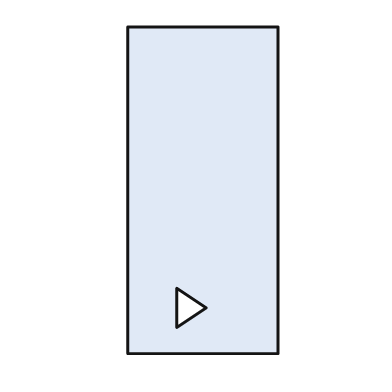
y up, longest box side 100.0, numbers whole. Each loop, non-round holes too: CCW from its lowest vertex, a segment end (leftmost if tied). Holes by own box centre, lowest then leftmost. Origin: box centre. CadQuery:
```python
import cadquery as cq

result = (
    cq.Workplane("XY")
    .moveTo(-23.0, -50.0)
    .lineTo(23.0, -50.0)
    .lineTo(23.0, 50.0)
    .lineTo(-23.0, 50.0)
    .close()
    .moveTo(-8.0, -42.0)
    .lineTo(1.0, -36.0)
    .lineTo(-8.0, -30.0)
    .close()
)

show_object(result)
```